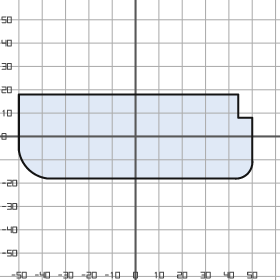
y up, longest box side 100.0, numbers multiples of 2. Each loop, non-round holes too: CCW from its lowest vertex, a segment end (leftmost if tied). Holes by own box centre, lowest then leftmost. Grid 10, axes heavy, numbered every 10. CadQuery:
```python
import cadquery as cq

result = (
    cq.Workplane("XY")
    .moveTo(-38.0, -18.0)
    .lineTo(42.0, -18.0)
    .threePointArc((48.0, -16.0), (50.0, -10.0))
    .lineTo(50.0, 8.0)
    .lineTo(44.0, 8.0)
    .lineTo(44.0, 18.0)
    .lineTo(-50.0, 18.0)
    .lineTo(-50.0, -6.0)
    .threePointArc((-46.0, -14.0), (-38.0, -18.0))
    .close()
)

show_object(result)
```